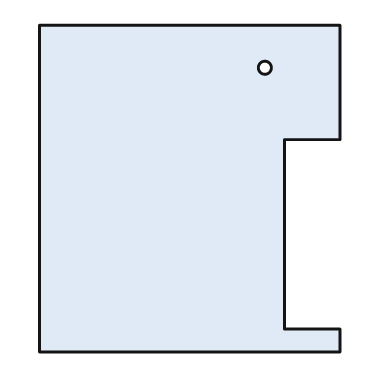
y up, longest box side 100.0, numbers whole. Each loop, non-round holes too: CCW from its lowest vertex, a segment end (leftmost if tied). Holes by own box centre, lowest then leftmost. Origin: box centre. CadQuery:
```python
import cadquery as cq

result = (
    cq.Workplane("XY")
    .moveTo(-46.0, -50.0)
    .lineTo(46.0, -50.0)
    .lineTo(46.0, -43.0)
    .lineTo(29.0, -43.0)
    .lineTo(29.0, 15.0)
    .lineTo(46.0, 15.0)
    .lineTo(46.0, 50.0)
    .lineTo(-46.0, 50.0)
    .close()
    .moveTo(23.0, 37.0)
    .circle(2.0)
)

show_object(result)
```